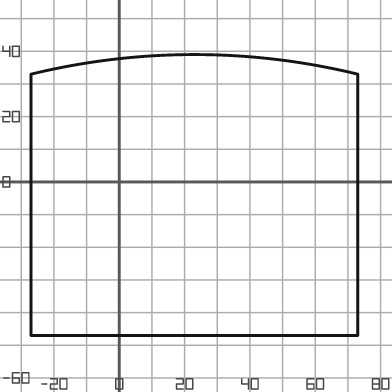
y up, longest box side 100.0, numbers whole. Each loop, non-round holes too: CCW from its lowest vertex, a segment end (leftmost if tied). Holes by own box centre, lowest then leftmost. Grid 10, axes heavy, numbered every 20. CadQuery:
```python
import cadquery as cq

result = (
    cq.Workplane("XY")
    .moveTo(-27.0, -47.0)
    .lineTo(73.0, -47.0)
    .lineTo(73.0, 33.0)
    .threePointArc((23.0, 39.0), (-27.0, 33.0))
    .close()
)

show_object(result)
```